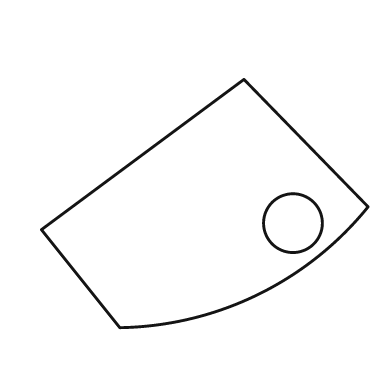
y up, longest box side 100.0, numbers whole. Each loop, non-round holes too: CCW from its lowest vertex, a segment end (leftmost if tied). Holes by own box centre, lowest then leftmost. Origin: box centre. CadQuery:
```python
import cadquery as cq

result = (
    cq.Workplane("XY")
    .moveTo(-26.0, -38.0)
    .threePointArc((16.0, -28.0), (50.0, -1.0))
    .lineTo(12.0, 38.0)
    .lineTo(-50.0, -8.0)
    .close()
    .moveTo(27.0, -6.0)
    .circle(9.0)
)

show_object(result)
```